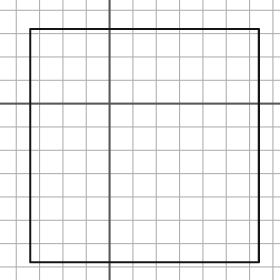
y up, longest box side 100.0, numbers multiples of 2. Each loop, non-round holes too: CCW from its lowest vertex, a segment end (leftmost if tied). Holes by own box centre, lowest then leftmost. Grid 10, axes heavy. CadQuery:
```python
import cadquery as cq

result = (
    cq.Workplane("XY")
    .moveTo(-34.0, -68.0)
    .lineTo(64.0, -68.0)
    .lineTo(64.0, 32.0)
    .lineTo(-34.0, 32.0)
    .close()
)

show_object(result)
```